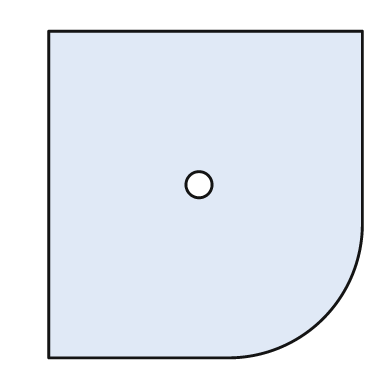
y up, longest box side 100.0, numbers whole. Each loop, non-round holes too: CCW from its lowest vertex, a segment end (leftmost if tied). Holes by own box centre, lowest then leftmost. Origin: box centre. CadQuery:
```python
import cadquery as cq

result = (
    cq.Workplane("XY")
    .moveTo(-48.0, -50.0)
    .lineTo(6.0, -50.0)
    .threePointArc((36.0, -38.0), (48.0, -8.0))
    .lineTo(48.0, 50.0)
    .lineTo(-48.0, 50.0)
    .close()
    .moveTo(-2.0, 3.0)
    .circle(4.0)
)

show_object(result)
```